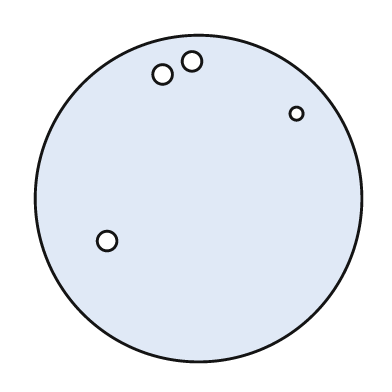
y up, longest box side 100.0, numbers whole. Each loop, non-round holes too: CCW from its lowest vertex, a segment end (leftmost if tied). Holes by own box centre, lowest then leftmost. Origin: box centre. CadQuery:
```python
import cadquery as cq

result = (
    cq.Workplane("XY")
    .moveTo(0.0, 0.0)
    .circle(50.0)
    .moveTo(-28.0, -13.0)
    .circle(3.0)
    .moveTo(30.0, 26.0)
    .circle(2.0)
    .moveTo(-11.0, 38.0)
    .circle(3.0)
    .moveTo(-2.0, 42.0)
    .circle(3.0)
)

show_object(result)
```